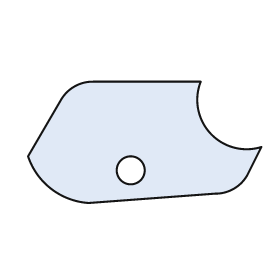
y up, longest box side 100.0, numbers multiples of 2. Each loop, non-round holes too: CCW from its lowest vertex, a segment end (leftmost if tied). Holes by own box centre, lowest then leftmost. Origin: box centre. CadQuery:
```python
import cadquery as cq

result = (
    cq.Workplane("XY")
    .moveTo(-24.0, -26.0)
    .lineTo(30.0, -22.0)
    .threePointArc((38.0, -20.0), (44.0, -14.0))
    .lineTo(50.0, -2.0)
    .threePointArc((28.0, 4.0), (24.0, 26.0))
    .lineTo(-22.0, 26.0)
    .threePointArc((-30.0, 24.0), (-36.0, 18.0))
    .lineTo(-50.0, -6.0)
    .threePointArc((-40.0, -20.0), (-24.0, -26.0))
    .close()
    .moveTo(-6.0, -12.0)
    .circle(6.0)
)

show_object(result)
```